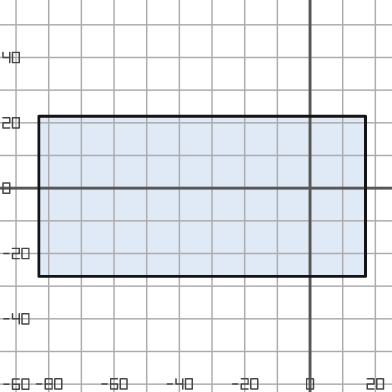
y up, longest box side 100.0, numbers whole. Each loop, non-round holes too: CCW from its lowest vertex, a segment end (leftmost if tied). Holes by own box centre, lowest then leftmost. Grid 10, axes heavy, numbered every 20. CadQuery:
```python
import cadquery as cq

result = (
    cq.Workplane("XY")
    .moveTo(-83.0, -27.0)
    .lineTo(17.0, -27.0)
    .lineTo(17.0, 22.0)
    .lineTo(-83.0, 22.0)
    .close()
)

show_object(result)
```